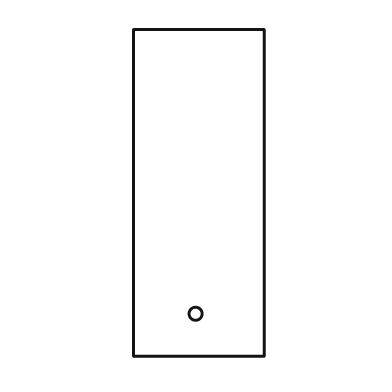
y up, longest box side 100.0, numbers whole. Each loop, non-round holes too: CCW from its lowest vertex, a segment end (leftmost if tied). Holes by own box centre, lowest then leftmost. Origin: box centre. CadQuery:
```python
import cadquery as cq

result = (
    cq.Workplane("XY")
    .moveTo(-20.0, -50.0)
    .lineTo(20.0, -50.0)
    .lineTo(20.0, 50.0)
    .lineTo(-20.0, 50.0)
    .close()
    .moveTo(-1.0, -37.0)
    .circle(2.0)
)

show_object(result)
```